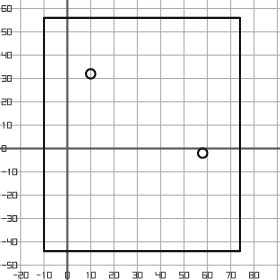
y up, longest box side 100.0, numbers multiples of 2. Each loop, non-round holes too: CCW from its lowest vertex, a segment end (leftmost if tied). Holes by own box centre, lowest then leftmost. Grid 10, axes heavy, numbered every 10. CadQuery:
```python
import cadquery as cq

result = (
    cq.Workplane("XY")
    .moveTo(-10.0, -44.0)
    .lineTo(74.0, -44.0)
    .lineTo(74.0, 56.0)
    .lineTo(-10.0, 56.0)
    .close()
    .moveTo(58.0, -2.0)
    .circle(2.0)
    .moveTo(10.0, 32.0)
    .circle(2.0)
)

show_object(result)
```